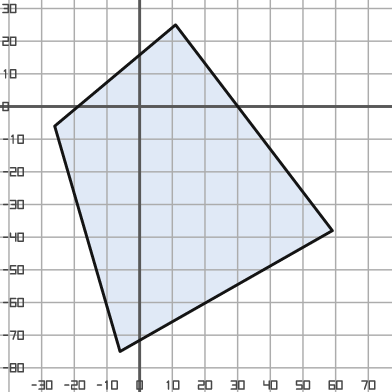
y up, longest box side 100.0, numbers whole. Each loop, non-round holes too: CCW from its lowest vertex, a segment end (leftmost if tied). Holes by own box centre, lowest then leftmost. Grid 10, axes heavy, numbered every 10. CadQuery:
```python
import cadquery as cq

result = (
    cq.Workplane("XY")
    .moveTo(-6.0, -75.0)
    .lineTo(59.0, -38.0)
    .lineTo(11.0, 25.0)
    .lineTo(-26.0, -6.0)
    .close()
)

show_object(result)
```